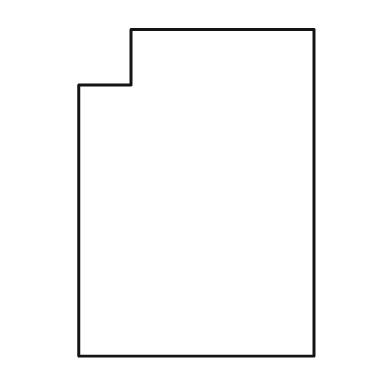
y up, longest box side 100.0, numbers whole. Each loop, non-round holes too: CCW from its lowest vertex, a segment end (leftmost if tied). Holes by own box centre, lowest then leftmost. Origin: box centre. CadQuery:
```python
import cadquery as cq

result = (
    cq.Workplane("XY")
    .moveTo(-36.0, -50.0)
    .lineTo(36.0, -50.0)
    .lineTo(36.0, 50.0)
    .lineTo(-20.0, 50.0)
    .lineTo(-20.0, 33.0)
    .lineTo(-36.0, 33.0)
    .close()
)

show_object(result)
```